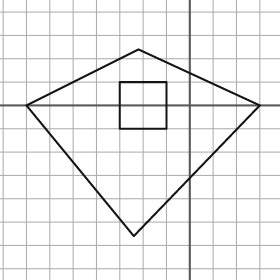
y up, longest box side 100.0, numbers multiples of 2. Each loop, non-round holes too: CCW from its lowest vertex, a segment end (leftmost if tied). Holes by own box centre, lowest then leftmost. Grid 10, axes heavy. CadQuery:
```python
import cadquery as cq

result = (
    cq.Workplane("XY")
    .moveTo(-24.0, -56.0)
    .lineTo(30.0, 0.0)
    .lineTo(-22.0, 24.0)
    .lineTo(-70.0, 0.0)
    .close()
    .moveTo(-30.0, -10.0)
    .lineTo(-10.0, -10.0)
    .lineTo(-10.0, 10.0)
    .lineTo(-30.0, 10.0)
    .close()
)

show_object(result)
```